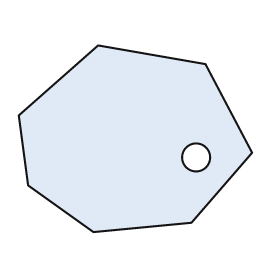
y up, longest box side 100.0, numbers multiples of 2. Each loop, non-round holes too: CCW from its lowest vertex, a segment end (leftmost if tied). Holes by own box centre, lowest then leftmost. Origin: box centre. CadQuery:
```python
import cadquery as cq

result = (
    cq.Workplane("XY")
    .moveTo(-18.0, -40.0)
    .lineTo(24.0, -36.0)
    .lineTo(50.0, -6.0)
    .lineTo(30.0, 32.0)
    .lineTo(-16.0, 40.0)
    .lineTo(-50.0, 10.0)
    .lineTo(-46.0, -20.0)
    .close()
    .moveTo(26.0, -8.0)
    .circle(6.0)
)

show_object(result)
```